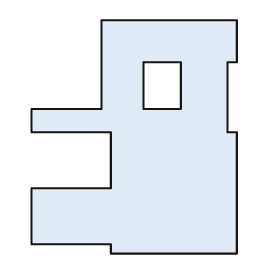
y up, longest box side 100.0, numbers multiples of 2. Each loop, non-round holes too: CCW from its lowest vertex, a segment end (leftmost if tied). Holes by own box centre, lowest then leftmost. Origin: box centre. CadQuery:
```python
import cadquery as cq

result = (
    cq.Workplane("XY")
    .moveTo(-10.0, -50.0)
    .lineTo(44.0, -50.0)
    .lineTo(44.0, 2.0)
    .lineTo(40.0, 2.0)
    .lineTo(40.0, 32.0)
    .lineTo(44.0, 32.0)
    .lineTo(44.0, 50.0)
    .lineTo(-14.0, 50.0)
    .lineTo(-14.0, 12.0)
    .lineTo(-44.0, 12.0)
    .lineTo(-44.0, 2.0)
    .lineTo(-10.0, 2.0)
    .lineTo(-10.0, -22.0)
    .lineTo(-44.0, -22.0)
    .lineTo(-44.0, -46.0)
    .lineTo(-10.0, -46.0)
    .close()
    .moveTo(4.0, 12.0)
    .lineTo(20.0, 12.0)
    .lineTo(20.0, 32.0)
    .lineTo(4.0, 32.0)
    .close()
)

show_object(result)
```